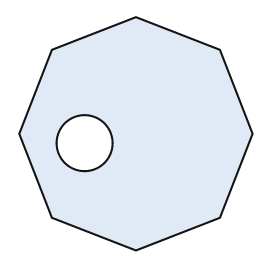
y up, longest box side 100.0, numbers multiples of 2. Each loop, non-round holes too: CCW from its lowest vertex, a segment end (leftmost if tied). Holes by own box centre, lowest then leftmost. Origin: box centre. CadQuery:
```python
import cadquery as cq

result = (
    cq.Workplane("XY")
    .moveTo(0.0, -50.0)
    .lineTo(36.0, -36.0)
    .lineTo(50.0, 0.0)
    .lineTo(36.0, 36.0)
    .lineTo(0.0, 50.0)
    .lineTo(-36.0, 36.0)
    .lineTo(-50.0, 0.0)
    .lineTo(-36.0, -36.0)
    .close()
    .moveTo(-22.0, -4.0)
    .circle(12.0)
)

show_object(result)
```